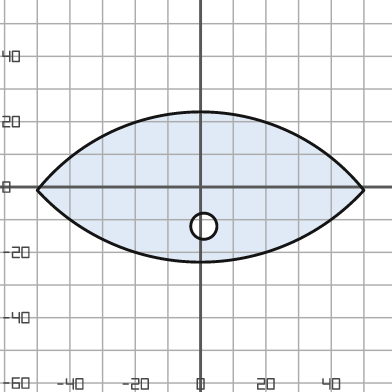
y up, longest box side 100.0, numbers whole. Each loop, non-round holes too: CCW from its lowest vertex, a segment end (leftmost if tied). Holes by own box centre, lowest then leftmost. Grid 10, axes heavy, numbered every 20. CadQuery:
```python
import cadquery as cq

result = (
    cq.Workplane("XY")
    .moveTo(-50.0, -1.0)
    .threePointArc((0.0, -23.0), (50.0, -1.0))
    .threePointArc((0.0, 23.0), (-50.0, -1.0))
    .close()
    .moveTo(1.0, -12.0)
    .circle(4.0)
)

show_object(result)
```